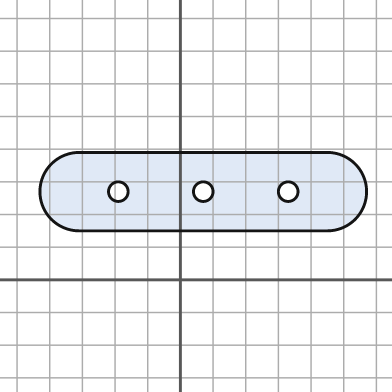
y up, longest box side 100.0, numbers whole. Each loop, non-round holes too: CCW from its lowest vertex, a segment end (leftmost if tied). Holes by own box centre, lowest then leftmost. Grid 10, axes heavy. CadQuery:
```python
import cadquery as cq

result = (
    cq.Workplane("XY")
    .moveTo(-31.0, 15.0)
    .lineTo(45.0, 15.0)
    .threePointArc((57.0, 27.0), (45.0, 39.0))
    .lineTo(-31.0, 39.0)
    .threePointArc((-43.0, 27.0), (-31.0, 15.0))
    .close()
    .moveTo(-19.0, 27.0)
    .circle(3.0)
    .moveTo(7.0, 27.0)
    .circle(3.0)
    .moveTo(33.0, 27.0)
    .circle(3.0)
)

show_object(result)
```